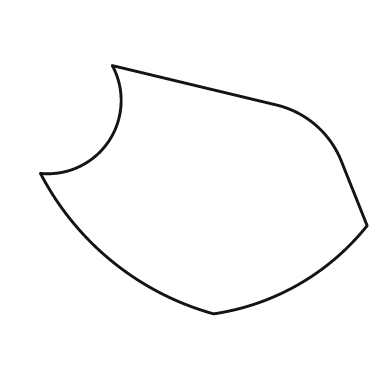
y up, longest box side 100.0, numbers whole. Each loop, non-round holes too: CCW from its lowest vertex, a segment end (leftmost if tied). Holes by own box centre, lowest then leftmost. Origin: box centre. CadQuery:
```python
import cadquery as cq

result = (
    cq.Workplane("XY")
    .moveTo(3.0, -38.0)
    .threePointArc((29.0, -29.0), (50.0, -11.0))
    .lineTo(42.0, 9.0)
    .threePointArc((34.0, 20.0), (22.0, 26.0))
    .lineTo(-28.0, 38.0)
    .threePointArc((-29.0, 15.0), (-50.0, 5.0))
    .threePointArc((-28.0, -22.0), (3.0, -38.0))
    .close()
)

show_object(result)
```